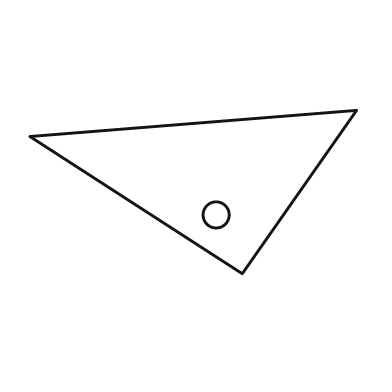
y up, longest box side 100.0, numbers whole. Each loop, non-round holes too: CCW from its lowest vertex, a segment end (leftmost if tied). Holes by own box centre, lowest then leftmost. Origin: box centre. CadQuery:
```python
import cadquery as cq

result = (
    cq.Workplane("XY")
    .moveTo(15.0, -25.0)
    .lineTo(50.0, 25.0)
    .lineTo(-50.0, 17.0)
    .close()
    .moveTo(7.0, -7.0)
    .circle(4.0)
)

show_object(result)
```